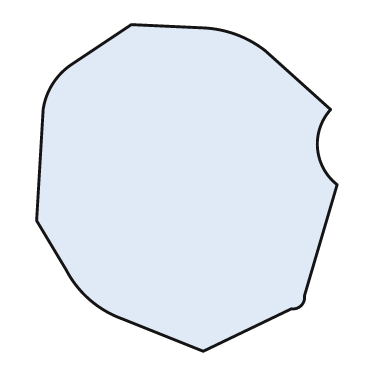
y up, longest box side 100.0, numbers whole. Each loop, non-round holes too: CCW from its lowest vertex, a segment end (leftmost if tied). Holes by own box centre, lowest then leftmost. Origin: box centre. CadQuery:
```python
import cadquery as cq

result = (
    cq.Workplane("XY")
    .moveTo(5.0, -50.0)
    .lineTo(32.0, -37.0)
    .threePointArc((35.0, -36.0), (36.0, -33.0))
    .lineTo(46.0, 1.0)
    .threePointArc((40.0, 12.0), (44.0, 24.0))
    .lineTo(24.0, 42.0)
    .threePointArc((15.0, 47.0), (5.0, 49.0))
    .lineTo(-17.0, 50.0)
    .lineTo(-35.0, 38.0)
    .threePointArc((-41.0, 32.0), (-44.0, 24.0))
    .lineTo(-46.0, -10.0)
    .lineTo(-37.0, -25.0)
    .threePointArc((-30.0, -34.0), (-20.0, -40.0))
    .close()
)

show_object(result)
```